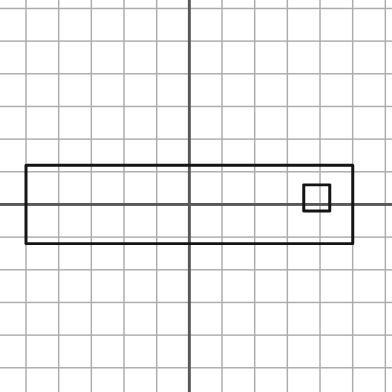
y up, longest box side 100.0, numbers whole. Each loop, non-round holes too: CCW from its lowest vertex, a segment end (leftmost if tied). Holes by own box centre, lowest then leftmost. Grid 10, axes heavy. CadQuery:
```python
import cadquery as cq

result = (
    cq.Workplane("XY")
    .moveTo(-50.0, -12.0)
    .lineTo(50.0, -12.0)
    .lineTo(50.0, 12.0)
    .lineTo(-50.0, 12.0)
    .close()
    .moveTo(35.0, -2.0)
    .lineTo(43.0, -2.0)
    .lineTo(43.0, 6.0)
    .lineTo(35.0, 6.0)
    .close()
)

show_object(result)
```